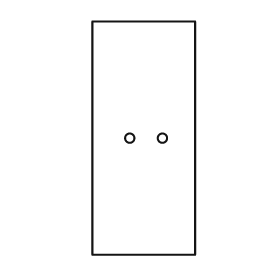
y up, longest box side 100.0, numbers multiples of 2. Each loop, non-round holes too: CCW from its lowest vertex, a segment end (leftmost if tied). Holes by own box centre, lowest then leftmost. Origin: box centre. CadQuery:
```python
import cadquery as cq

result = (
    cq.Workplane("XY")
    .moveTo(-22.0, -50.0)
    .lineTo(22.0, -50.0)
    .lineTo(22.0, 50.0)
    .lineTo(-22.0, 50.0)
    .close()
    .moveTo(-6.0, 0.0)
    .circle(2.0)
    .moveTo(8.0, 0.0)
    .circle(2.0)
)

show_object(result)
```